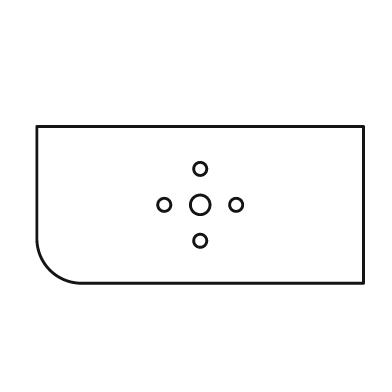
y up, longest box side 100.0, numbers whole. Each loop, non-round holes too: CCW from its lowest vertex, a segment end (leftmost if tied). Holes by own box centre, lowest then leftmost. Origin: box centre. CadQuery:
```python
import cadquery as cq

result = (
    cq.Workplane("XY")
    .moveTo(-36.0, -24.0)
    .lineTo(50.0, -24.0)
    .lineTo(50.0, 24.0)
    .lineTo(-50.0, 24.0)
    .lineTo(-50.0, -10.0)
    .threePointArc((-46.0, -20.0), (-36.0, -24.0))
    .close()
    .moveTo(0.0, -11.0)
    .circle(2.0)
    .moveTo(-11.0, 0.0)
    .circle(2.0)
    .moveTo(0.0, 0.0)
    .circle(3.0)
    .moveTo(11.0, 0.0)
    .circle(2.0)
    .moveTo(0.0, 11.0)
    .circle(2.0)
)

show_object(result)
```